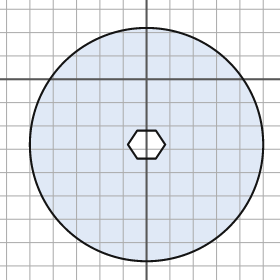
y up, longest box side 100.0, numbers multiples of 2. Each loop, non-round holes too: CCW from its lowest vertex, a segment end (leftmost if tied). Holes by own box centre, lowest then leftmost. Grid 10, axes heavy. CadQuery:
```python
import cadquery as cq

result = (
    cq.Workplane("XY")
    .moveTo(0.0, -28.0)
    .circle(50.0)
    .moveTo(-4.0, -34.0)
    .lineTo(4.0, -34.0)
    .lineTo(8.0, -28.0)
    .lineTo(4.0, -22.0)
    .lineTo(-4.0, -22.0)
    .lineTo(-8.0, -28.0)
    .close()
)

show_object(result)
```